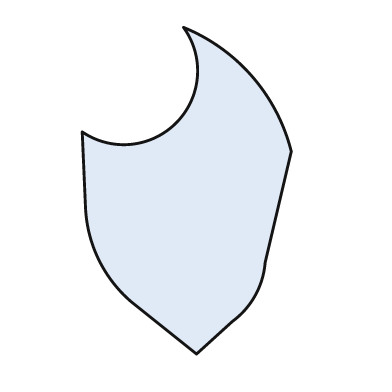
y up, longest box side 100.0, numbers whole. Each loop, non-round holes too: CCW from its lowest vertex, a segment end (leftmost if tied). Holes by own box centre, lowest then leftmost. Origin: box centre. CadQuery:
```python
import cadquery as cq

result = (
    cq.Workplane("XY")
    .moveTo(3.0, -50.0)
    .lineTo(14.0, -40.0)
    .threePointArc((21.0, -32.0), (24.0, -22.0))
    .lineTo(32.0, 12.0)
    .threePointArc((20.0, 35.0), (-1.0, 50.0))
    .threePointArc((-3.0, 21.0), (-32.0, 18.0))
    .lineTo(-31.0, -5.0)
    .threePointArc((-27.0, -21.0), (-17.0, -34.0))
    .close()
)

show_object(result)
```